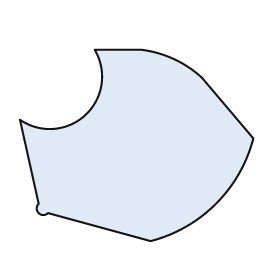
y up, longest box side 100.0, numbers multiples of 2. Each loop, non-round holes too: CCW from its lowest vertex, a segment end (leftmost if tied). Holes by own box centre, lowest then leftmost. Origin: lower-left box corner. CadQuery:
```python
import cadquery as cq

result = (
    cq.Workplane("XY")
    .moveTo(56.0, 0.0)
    .threePointArc((84.0, 16.0), (100.0, 44.0))
    .lineTo(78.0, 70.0)
    .threePointArc((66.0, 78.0), (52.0, 82.0))
    .lineTo(32.0, 82.0)
    .threePointArc((28.0, 54.0), (0.0, 52.0))
    .lineTo(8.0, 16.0)
    .threePointArc((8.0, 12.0), (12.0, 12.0))
    .close()
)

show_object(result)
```